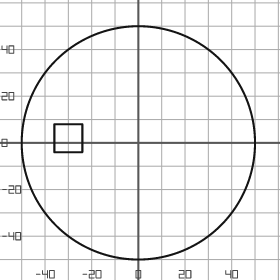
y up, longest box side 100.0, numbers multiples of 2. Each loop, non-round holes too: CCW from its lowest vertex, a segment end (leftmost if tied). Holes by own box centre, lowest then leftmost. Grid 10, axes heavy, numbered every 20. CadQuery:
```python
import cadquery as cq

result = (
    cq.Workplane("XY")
    .moveTo(0.0, 0.0)
    .circle(50.0)
    .moveTo(-36.0, -4.0)
    .lineTo(-24.0, -4.0)
    .lineTo(-24.0, 8.0)
    .lineTo(-36.0, 8.0)
    .close()
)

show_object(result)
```